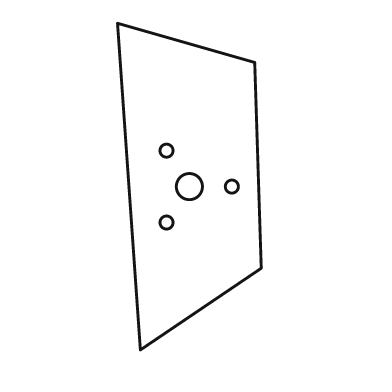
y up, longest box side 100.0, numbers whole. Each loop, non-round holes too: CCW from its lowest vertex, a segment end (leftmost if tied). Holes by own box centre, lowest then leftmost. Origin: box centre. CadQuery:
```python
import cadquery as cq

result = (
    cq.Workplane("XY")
    .moveTo(-15.0, -50.0)
    .lineTo(22.0, -25.0)
    .lineTo(20.0, 38.0)
    .lineTo(-22.0, 50.0)
    .close()
    .moveTo(-7.0, -11.0)
    .circle(2.0)
    .moveTo(0.0, 0.0)
    .circle(4.0)
    .moveTo(13.0, 0.0)
    .circle(2.0)
    .moveTo(-7.0, 11.0)
    .circle(2.0)
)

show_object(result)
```